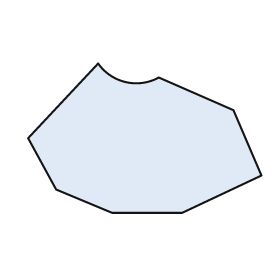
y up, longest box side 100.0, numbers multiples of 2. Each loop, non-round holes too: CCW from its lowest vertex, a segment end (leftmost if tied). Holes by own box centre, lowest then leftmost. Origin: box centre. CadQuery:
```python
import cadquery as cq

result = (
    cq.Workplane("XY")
    .moveTo(-14.0, -32.0)
    .lineTo(16.0, -32.0)
    .lineTo(50.0, -16.0)
    .lineTo(38.0, 12.0)
    .lineTo(6.0, 26.0)
    .threePointArc((-8.0, 24.0), (-20.0, 32.0))
    .lineTo(-50.0, 0.0)
    .lineTo(-38.0, -22.0)
    .close()
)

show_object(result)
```